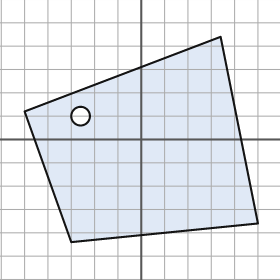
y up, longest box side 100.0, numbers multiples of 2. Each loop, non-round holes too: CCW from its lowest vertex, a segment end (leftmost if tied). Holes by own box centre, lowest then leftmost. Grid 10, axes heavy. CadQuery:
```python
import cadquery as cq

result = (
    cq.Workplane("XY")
    .moveTo(-30.0, -44.0)
    .lineTo(50.0, -36.0)
    .lineTo(34.0, 44.0)
    .lineTo(-50.0, 12.0)
    .close()
    .moveTo(-26.0, 10.0)
    .circle(4.0)
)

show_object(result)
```